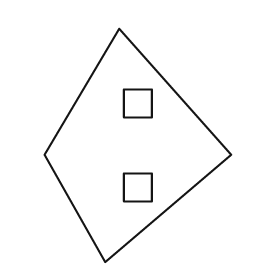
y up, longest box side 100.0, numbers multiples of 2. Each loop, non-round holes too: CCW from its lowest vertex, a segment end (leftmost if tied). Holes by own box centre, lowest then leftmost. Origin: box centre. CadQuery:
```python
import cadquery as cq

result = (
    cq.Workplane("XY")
    .moveTo(-14.0, -50.0)
    .lineTo(40.0, -4.0)
    .lineTo(-8.0, 50.0)
    .lineTo(-40.0, -4.0)
    .close()
    .moveTo(-6.0, -24.0)
    .lineTo(6.0, -24.0)
    .lineTo(6.0, -12.0)
    .lineTo(-6.0, -12.0)
    .close()
    .moveTo(-6.0, 12.0)
    .lineTo(6.0, 12.0)
    .lineTo(6.0, 24.0)
    .lineTo(-6.0, 24.0)
    .close()
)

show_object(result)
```